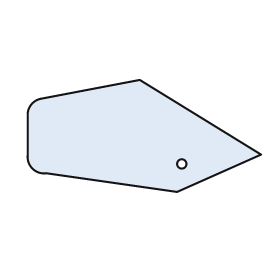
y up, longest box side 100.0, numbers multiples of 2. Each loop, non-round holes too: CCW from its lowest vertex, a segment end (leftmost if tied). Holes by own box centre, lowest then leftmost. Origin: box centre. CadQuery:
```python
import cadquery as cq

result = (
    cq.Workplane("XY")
    .moveTo(14.0, -24.0)
    .lineTo(50.0, -8.0)
    .lineTo(-2.0, 24.0)
    .lineTo(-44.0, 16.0)
    .threePointArc((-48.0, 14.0), (-50.0, 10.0))
    .lineTo(-50.0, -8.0)
    .threePointArc((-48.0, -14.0), (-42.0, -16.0))
    .close()
    .moveTo(16.0, -12.0)
    .circle(2.0)
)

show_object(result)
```